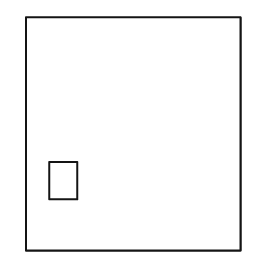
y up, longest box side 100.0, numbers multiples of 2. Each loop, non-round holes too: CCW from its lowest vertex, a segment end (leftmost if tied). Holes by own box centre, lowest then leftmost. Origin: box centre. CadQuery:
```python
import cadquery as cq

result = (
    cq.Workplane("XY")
    .moveTo(-46.0, -50.0)
    .lineTo(46.0, -50.0)
    .lineTo(46.0, 50.0)
    .lineTo(-46.0, 50.0)
    .close()
    .moveTo(-36.0, -28.0)
    .lineTo(-24.0, -28.0)
    .lineTo(-24.0, -12.0)
    .lineTo(-36.0, -12.0)
    .close()
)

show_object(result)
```